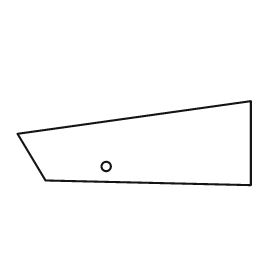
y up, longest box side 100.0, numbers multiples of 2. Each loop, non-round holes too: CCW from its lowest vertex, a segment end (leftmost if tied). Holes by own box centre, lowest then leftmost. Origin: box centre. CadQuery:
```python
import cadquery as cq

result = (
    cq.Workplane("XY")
    .moveTo(50.0, -18.0)
    .lineTo(50.0, 18.0)
    .lineTo(-50.0, 4.0)
    .lineTo(-38.0, -16.0)
    .close()
    .moveTo(-12.0, -10.0)
    .circle(2.0)
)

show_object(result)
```